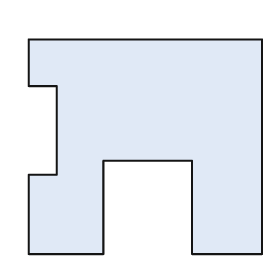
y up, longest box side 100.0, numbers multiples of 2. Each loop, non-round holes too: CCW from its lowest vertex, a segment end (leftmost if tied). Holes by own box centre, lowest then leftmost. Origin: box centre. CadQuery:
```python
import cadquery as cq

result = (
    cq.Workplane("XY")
    .moveTo(-50.0, -46.0)
    .lineTo(-18.0, -46.0)
    .lineTo(-18.0, -6.0)
    .lineTo(20.0, -6.0)
    .lineTo(20.0, -46.0)
    .lineTo(50.0, -46.0)
    .lineTo(50.0, 46.0)
    .lineTo(-50.0, 46.0)
    .lineTo(-50.0, 26.0)
    .lineTo(-38.0, 26.0)
    .lineTo(-38.0, -12.0)
    .lineTo(-50.0, -12.0)
    .close()
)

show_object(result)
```